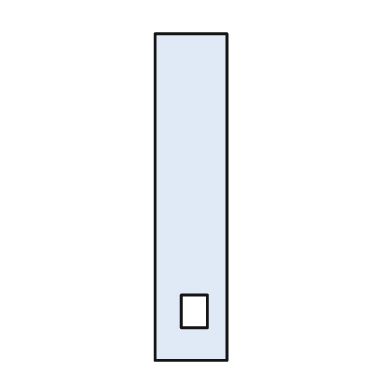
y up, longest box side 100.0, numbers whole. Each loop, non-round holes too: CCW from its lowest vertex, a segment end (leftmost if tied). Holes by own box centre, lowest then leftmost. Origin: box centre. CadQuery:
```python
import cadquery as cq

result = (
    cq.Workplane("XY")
    .moveTo(-11.0, -50.0)
    .lineTo(11.0, -50.0)
    .lineTo(11.0, 50.0)
    .lineTo(-11.0, 50.0)
    .close()
    .moveTo(-3.0, -40.0)
    .lineTo(5.0, -40.0)
    .lineTo(5.0, -30.0)
    .lineTo(-3.0, -30.0)
    .close()
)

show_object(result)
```